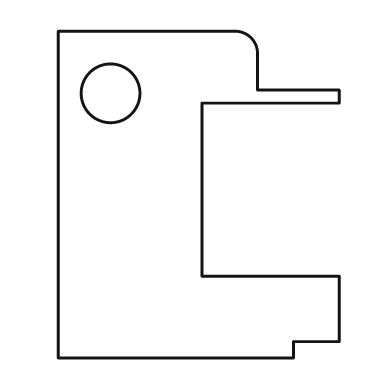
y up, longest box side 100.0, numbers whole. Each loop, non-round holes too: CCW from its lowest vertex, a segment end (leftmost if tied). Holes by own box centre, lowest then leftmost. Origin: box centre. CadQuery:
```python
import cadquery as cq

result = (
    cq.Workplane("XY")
    .moveTo(-43.0, -50.0)
    .lineTo(29.0, -50.0)
    .lineTo(29.0, -45.0)
    .lineTo(43.0, -45.0)
    .lineTo(43.0, -25.0)
    .lineTo(1.0, -25.0)
    .lineTo(1.0, 28.0)
    .lineTo(43.0, 28.0)
    .lineTo(43.0, 32.0)
    .lineTo(18.0, 32.0)
    .lineTo(18.0, 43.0)
    .threePointArc((16.0, 48.0), (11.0, 50.0))
    .lineTo(-43.0, 50.0)
    .close()
    .moveTo(-27.0, 31.0)
    .circle(9.0)
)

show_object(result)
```